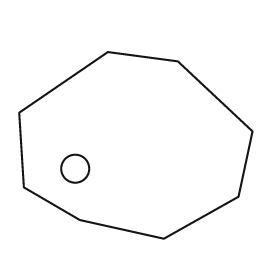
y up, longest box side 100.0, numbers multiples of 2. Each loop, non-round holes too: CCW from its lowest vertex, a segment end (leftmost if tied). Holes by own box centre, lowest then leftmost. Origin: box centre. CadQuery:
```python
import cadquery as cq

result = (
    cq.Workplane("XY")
    .moveTo(12.0, -40.0)
    .lineTo(44.0, -22.0)
    .lineTo(50.0, 6.0)
    .lineTo(18.0, 36.0)
    .lineTo(-12.0, 40.0)
    .lineTo(-50.0, 14.0)
    .lineTo(-48.0, -18.0)
    .lineTo(-24.0, -32.0)
    .close()
    .moveTo(-26.0, -10.0)
    .circle(6.0)
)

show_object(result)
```